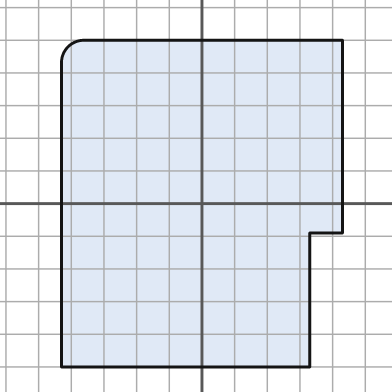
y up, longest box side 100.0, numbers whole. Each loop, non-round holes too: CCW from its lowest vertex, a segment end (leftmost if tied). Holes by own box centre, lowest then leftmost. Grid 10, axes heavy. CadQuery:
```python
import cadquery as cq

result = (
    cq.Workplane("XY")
    .moveTo(-43.0, -50.0)
    .lineTo(33.0, -50.0)
    .lineTo(33.0, -9.0)
    .lineTo(43.0, -9.0)
    .lineTo(43.0, 50.0)
    .lineTo(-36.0, 50.0)
    .threePointArc((-41.0, 48.0), (-43.0, 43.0))
    .close()
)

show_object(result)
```